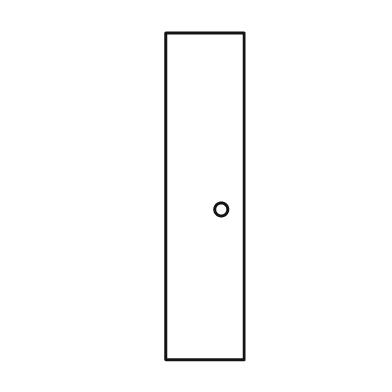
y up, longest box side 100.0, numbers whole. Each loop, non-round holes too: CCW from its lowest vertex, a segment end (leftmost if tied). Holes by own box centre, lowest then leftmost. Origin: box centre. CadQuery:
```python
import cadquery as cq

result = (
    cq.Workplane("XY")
    .moveTo(-12.0, -50.0)
    .lineTo(12.0, -50.0)
    .lineTo(12.0, 50.0)
    .lineTo(-12.0, 50.0)
    .close()
    .moveTo(5.0, -4.0)
    .circle(2.0)
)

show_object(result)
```